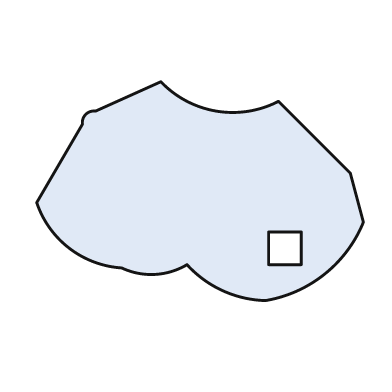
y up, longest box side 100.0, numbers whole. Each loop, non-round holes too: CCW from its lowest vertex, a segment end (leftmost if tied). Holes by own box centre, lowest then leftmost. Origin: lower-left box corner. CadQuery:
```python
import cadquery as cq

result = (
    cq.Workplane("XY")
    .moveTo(70.0, 0.0)
    .threePointArc((88.0, 8.0), (100.0, 24.0))
    .lineTo(96.0, 39.0)
    .lineTo(74.0, 61.0)
    .threePointArc((55.0, 58.0), (38.0, 67.0))
    .lineTo(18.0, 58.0)
    .threePointArc((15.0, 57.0), (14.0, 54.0))
    .lineTo(0.0, 30.0)
    .threePointArc((10.0, 16.0), (26.0, 10.0))
    .threePointArc((36.0, 8.0), (46.0, 11.0))
    .threePointArc((57.0, 3.0), (70.0, 0.0))
    .close()
    .moveTo(71.0, 11.0)
    .lineTo(81.0, 11.0)
    .lineTo(81.0, 21.0)
    .lineTo(71.0, 21.0)
    .close()
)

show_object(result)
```